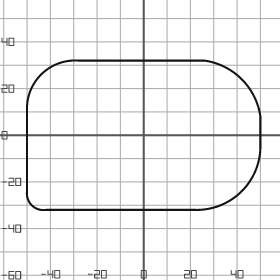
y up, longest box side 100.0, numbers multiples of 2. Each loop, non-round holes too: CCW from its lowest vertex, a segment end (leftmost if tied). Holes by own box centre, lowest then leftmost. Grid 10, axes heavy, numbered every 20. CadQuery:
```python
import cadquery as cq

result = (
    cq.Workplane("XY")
    .moveTo(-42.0, -32.0)
    .lineTo(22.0, -32.0)
    .threePointArc((42.0, -24.0), (50.0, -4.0))
    .lineTo(50.0, 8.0)
    .threePointArc((42.0, 24.0), (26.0, 32.0))
    .lineTo(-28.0, 32.0)
    .threePointArc((-44.0, 26.0), (-50.0, 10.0))
    .lineTo(-50.0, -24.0)
    .threePointArc((-48.0, -30.0), (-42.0, -32.0))
    .close()
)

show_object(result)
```